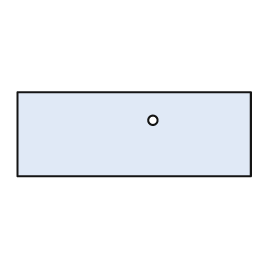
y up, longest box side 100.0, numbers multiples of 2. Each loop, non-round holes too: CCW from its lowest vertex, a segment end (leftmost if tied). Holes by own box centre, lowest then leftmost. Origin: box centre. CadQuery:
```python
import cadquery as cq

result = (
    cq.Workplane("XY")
    .moveTo(-50.0, -18.0)
    .lineTo(50.0, -18.0)
    .lineTo(50.0, 18.0)
    .lineTo(-50.0, 18.0)
    .close()
    .moveTo(8.0, 6.0)
    .circle(2.0)
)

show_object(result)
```